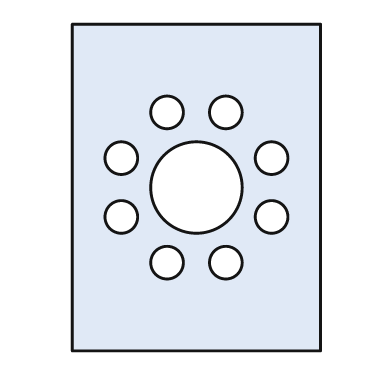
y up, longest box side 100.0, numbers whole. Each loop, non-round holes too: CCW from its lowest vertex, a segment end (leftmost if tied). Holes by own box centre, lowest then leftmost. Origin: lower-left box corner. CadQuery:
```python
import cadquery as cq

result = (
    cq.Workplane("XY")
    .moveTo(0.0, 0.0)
    .lineTo(76.0, 0.0)
    .lineTo(76.0, 100.0)
    .lineTo(0.0, 100.0)
    .close()
    .moveTo(29.0, 27.0)
    .circle(5.0)
    .moveTo(47.0, 27.0)
    .circle(5.0)
    .moveTo(15.0, 41.0)
    .circle(5.0)
    .moveTo(61.0, 41.0)
    .circle(5.0)
    .moveTo(38.0, 50.0)
    .circle(14.0)
    .moveTo(15.0, 59.0)
    .circle(5.0)
    .moveTo(61.0, 59.0)
    .circle(5.0)
    .moveTo(29.0, 73.0)
    .circle(5.0)
    .moveTo(47.0, 73.0)
    .circle(5.0)
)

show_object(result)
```